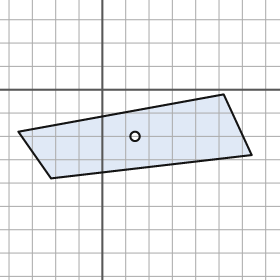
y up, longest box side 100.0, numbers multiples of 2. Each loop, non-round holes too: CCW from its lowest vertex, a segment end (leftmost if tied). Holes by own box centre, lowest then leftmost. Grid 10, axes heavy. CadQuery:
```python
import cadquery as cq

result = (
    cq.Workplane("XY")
    .moveTo(-22.0, -38.0)
    .lineTo(64.0, -28.0)
    .lineTo(52.0, -2.0)
    .lineTo(-36.0, -18.0)
    .close()
    .moveTo(14.0, -20.0)
    .circle(2.0)
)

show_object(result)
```